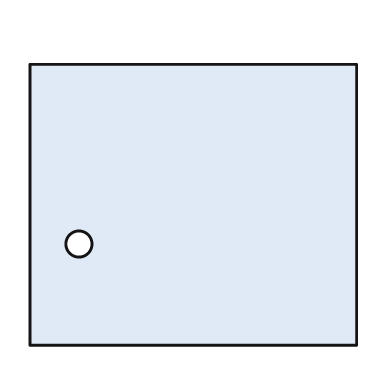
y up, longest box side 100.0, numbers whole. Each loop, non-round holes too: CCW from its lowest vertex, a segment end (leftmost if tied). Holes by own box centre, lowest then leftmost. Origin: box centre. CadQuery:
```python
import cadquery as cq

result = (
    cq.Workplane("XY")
    .moveTo(-50.0, -43.0)
    .lineTo(50.0, -43.0)
    .lineTo(50.0, 43.0)
    .lineTo(-50.0, 43.0)
    .close()
    .moveTo(-35.0, -12.0)
    .circle(4.0)
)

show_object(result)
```